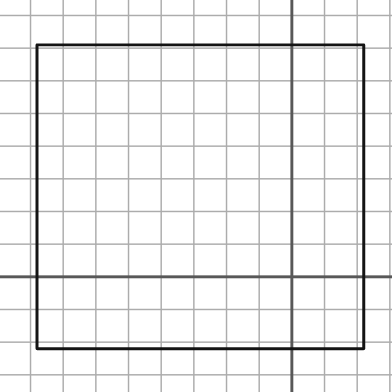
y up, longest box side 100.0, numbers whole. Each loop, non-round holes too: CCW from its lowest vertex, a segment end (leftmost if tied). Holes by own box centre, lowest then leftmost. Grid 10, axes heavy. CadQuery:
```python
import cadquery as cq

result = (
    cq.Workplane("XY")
    .moveTo(-78.0, -22.0)
    .lineTo(22.0, -22.0)
    .lineTo(22.0, 71.0)
    .lineTo(-78.0, 71.0)
    .close()
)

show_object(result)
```